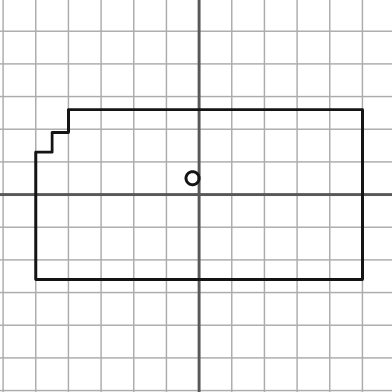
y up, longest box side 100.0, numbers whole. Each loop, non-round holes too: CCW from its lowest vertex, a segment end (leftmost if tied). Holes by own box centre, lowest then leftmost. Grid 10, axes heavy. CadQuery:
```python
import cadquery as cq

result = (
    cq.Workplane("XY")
    .moveTo(-50.0, -26.0)
    .lineTo(50.0, -26.0)
    .lineTo(50.0, 26.0)
    .lineTo(-40.0, 26.0)
    .lineTo(-40.0, 19.0)
    .lineTo(-45.0, 19.0)
    .lineTo(-45.0, 13.0)
    .lineTo(-50.0, 13.0)
    .close()
    .moveTo(-2.0, 5.0)
    .circle(2.0)
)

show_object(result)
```